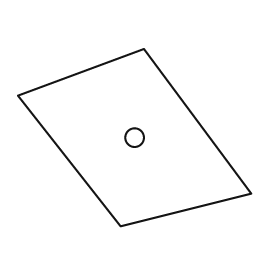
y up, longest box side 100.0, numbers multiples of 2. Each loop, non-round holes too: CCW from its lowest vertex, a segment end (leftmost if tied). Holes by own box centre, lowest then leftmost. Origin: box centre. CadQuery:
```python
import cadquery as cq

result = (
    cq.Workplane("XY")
    .moveTo(-6.0, -38.0)
    .lineTo(50.0, -24.0)
    .lineTo(4.0, 38.0)
    .lineTo(-50.0, 18.0)
    .close()
    .moveTo(0.0, 0.0)
    .circle(4.0)
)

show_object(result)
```